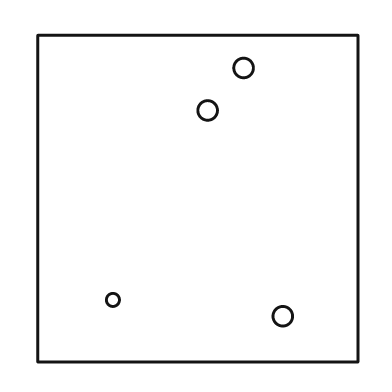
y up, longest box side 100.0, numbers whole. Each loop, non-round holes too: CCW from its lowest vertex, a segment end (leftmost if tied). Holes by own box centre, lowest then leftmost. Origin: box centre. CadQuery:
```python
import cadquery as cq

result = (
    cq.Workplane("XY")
    .moveTo(-49.0, -50.0)
    .lineTo(49.0, -50.0)
    .lineTo(49.0, 50.0)
    .lineTo(-49.0, 50.0)
    .close()
    .moveTo(26.0, -36.0)
    .circle(3.0)
    .moveTo(-26.0, -31.0)
    .circle(2.0)
    .moveTo(3.0, 27.0)
    .circle(3.0)
    .moveTo(14.0, 40.0)
    .circle(3.0)
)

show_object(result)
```